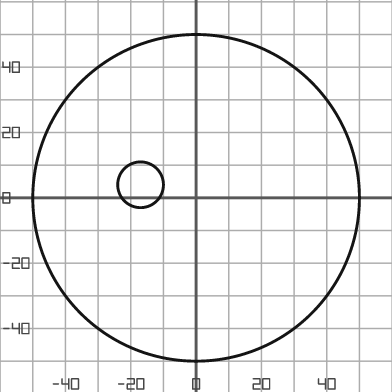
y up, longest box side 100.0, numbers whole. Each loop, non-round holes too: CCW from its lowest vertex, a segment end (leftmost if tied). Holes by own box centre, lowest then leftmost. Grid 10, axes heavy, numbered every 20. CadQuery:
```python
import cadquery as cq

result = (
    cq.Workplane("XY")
    .moveTo(0.0, 0.0)
    .circle(50.0)
    .moveTo(-17.0, 4.0)
    .circle(7.0)
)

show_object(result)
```